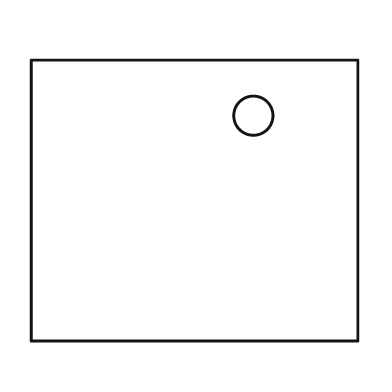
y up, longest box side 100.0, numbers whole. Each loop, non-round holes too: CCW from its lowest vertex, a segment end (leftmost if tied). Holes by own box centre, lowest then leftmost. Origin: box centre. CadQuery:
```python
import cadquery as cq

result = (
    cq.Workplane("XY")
    .moveTo(-50.0, -43.0)
    .lineTo(50.0, -43.0)
    .lineTo(50.0, 43.0)
    .lineTo(-50.0, 43.0)
    .close()
    .moveTo(18.0, 26.0)
    .circle(6.0)
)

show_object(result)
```